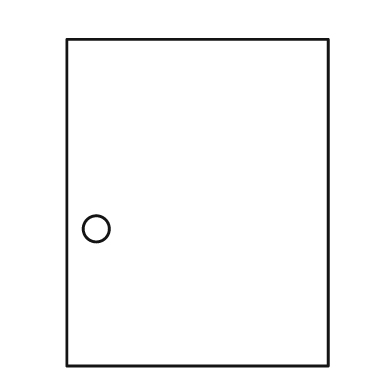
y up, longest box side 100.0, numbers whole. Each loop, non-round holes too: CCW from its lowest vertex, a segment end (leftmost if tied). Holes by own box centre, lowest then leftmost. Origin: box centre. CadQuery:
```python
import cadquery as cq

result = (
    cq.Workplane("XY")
    .moveTo(-40.0, -50.0)
    .lineTo(40.0, -50.0)
    .lineTo(40.0, 50.0)
    .lineTo(-40.0, 50.0)
    .close()
    .moveTo(-31.0, -8.0)
    .circle(4.0)
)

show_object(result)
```